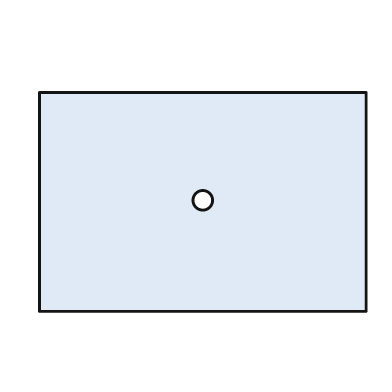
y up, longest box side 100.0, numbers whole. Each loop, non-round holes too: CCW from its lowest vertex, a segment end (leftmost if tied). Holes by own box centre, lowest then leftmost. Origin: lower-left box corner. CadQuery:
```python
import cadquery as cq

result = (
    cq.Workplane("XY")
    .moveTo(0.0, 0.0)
    .lineTo(100.0, 0.0)
    .lineTo(100.0, 67.0)
    .lineTo(0.0, 67.0)
    .close()
    .moveTo(50.0, 34.0)
    .circle(3.0)
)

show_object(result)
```